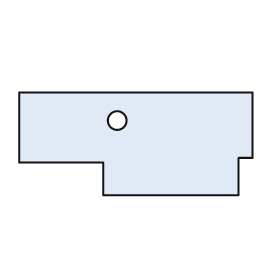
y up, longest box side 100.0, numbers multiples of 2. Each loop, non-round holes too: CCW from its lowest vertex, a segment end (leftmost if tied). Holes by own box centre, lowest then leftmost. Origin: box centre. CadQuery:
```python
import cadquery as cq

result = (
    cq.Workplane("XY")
    .moveTo(-14.0, -22.0)
    .lineTo(44.0, -22.0)
    .lineTo(44.0, -6.0)
    .lineTo(50.0, -6.0)
    .lineTo(50.0, 22.0)
    .lineTo(-50.0, 22.0)
    .lineTo(-50.0, -8.0)
    .lineTo(-14.0, -8.0)
    .close()
    .moveTo(-8.0, 10.0)
    .circle(4.0)
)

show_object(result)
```